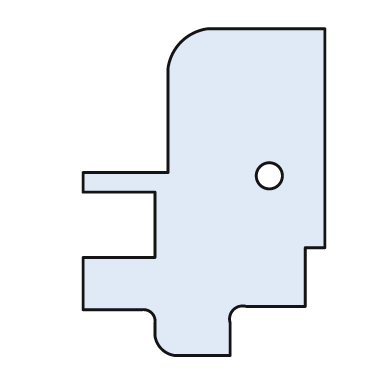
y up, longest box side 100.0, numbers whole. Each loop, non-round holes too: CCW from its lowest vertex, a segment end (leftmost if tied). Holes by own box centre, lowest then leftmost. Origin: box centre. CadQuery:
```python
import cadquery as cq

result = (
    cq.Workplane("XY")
    .moveTo(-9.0, -50.0)
    .lineTo(8.0, -50.0)
    .lineTo(8.0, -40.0)
    .threePointArc((9.0, -36.0), (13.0, -35.0))
    .lineTo(31.0, -35.0)
    .lineTo(31.0, -17.0)
    .lineTo(37.0, -17.0)
    .lineTo(37.0, 50.0)
    .lineTo(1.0, 50.0)
    .threePointArc((-7.0, 46.0), (-11.0, 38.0))
    .lineTo(-11.0, 6.0)
    .lineTo(-37.0, 6.0)
    .lineTo(-37.0, 0.0)
    .lineTo(-15.0, 0.0)
    .lineTo(-15.0, -20.0)
    .lineTo(-37.0, -20.0)
    .lineTo(-37.0, -36.0)
    .lineTo(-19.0, -36.0)
    .threePointArc((-16.0, -37.0), (-15.0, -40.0))
    .lineTo(-15.0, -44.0)
    .threePointArc((-13.0, -48.0), (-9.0, -50.0))
    .close()
    .moveTo(20.0, 5.0)
    .circle(4.0)
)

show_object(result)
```